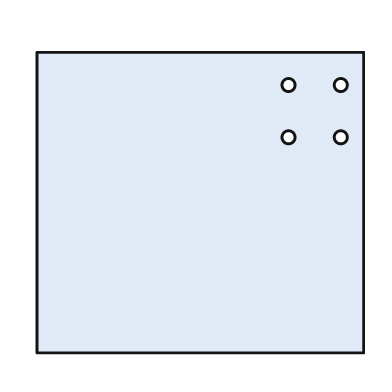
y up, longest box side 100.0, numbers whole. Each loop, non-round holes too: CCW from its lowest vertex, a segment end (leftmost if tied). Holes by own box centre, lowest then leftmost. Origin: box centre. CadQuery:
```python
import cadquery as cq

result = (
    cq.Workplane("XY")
    .moveTo(-50.0, -46.0)
    .lineTo(50.0, -46.0)
    .lineTo(50.0, 46.0)
    .lineTo(-50.0, 46.0)
    .close()
    .moveTo(27.0, 20.0)
    .circle(2.0)
    .moveTo(43.0, 20.0)
    .circle(2.0)
    .moveTo(27.0, 36.0)
    .circle(2.0)
    .moveTo(43.0, 36.0)
    .circle(2.0)
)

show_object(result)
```